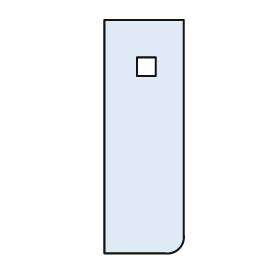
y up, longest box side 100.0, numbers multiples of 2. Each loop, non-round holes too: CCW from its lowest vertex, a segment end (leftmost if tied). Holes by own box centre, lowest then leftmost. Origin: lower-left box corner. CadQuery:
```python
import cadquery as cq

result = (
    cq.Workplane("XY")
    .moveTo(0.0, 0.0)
    .lineTo(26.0, 0.0)
    .threePointArc((32.0, 2.0), (34.0, 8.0))
    .lineTo(34.0, 100.0)
    .lineTo(0.0, 100.0)
    .close()
    .moveTo(14.0, 76.0)
    .lineTo(22.0, 76.0)
    .lineTo(22.0, 84.0)
    .lineTo(14.0, 84.0)
    .close()
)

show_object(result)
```